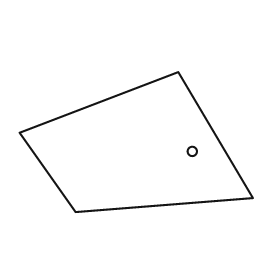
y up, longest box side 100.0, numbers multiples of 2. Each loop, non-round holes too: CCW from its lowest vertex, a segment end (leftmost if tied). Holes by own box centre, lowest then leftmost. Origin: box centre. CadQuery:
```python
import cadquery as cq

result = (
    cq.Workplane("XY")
    .moveTo(-26.0, -30.0)
    .lineTo(50.0, -24.0)
    .lineTo(18.0, 30.0)
    .lineTo(-50.0, 4.0)
    .close()
    .moveTo(24.0, -4.0)
    .circle(2.0)
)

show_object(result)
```